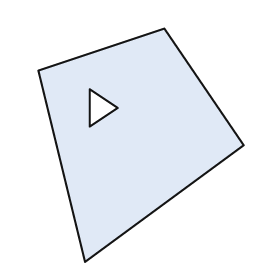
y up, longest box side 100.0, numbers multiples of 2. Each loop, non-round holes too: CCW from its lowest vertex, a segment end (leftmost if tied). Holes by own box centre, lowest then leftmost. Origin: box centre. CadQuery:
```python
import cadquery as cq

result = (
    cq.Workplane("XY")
    .moveTo(-24.0, -50.0)
    .lineTo(44.0, 0.0)
    .lineTo(10.0, 50.0)
    .lineTo(-44.0, 32.0)
    .close()
    .moveTo(-22.0, 8.0)
    .lineTo(-10.0, 16.0)
    .lineTo(-22.0, 24.0)
    .close()
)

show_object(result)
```